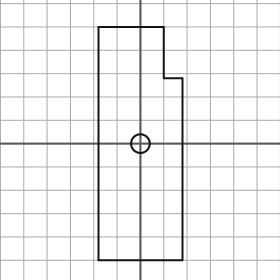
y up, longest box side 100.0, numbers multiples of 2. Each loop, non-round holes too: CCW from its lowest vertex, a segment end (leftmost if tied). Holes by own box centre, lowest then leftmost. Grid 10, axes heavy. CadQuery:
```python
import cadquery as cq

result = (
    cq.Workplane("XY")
    .moveTo(-18.0, -50.0)
    .lineTo(18.0, -50.0)
    .lineTo(18.0, 28.0)
    .lineTo(10.0, 28.0)
    .lineTo(10.0, 50.0)
    .lineTo(-18.0, 50.0)
    .close()
    .moveTo(0.0, 0.0)
    .circle(4.0)
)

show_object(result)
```